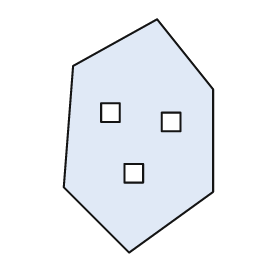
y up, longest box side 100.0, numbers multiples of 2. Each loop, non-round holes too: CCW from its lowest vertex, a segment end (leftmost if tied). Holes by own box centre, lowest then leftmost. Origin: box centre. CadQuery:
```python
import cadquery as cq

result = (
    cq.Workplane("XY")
    .moveTo(-4.0, -50.0)
    .lineTo(32.0, -24.0)
    .lineTo(32.0, 20.0)
    .lineTo(8.0, 50.0)
    .lineTo(-28.0, 30.0)
    .lineTo(-32.0, -22.0)
    .close()
    .moveTo(-6.0, -20.0)
    .lineTo(2.0, -20.0)
    .lineTo(2.0, -12.0)
    .lineTo(-6.0, -12.0)
    .close()
    .moveTo(10.0, 2.0)
    .lineTo(18.0, 2.0)
    .lineTo(18.0, 10.0)
    .lineTo(10.0, 10.0)
    .close()
    .moveTo(-16.0, 6.0)
    .lineTo(-8.0, 6.0)
    .lineTo(-8.0, 14.0)
    .lineTo(-16.0, 14.0)
    .close()
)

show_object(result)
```